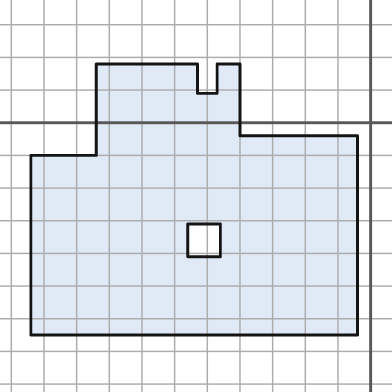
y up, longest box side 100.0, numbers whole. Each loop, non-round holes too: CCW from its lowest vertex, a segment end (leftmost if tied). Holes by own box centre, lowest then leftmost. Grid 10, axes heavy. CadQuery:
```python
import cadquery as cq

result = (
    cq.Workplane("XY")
    .moveTo(-104.0, -65.0)
    .lineTo(-4.0, -65.0)
    .lineTo(-4.0, -4.0)
    .lineTo(-40.0, -4.0)
    .lineTo(-40.0, 18.0)
    .lineTo(-47.0, 18.0)
    .lineTo(-47.0, 9.0)
    .lineTo(-53.0, 9.0)
    .lineTo(-53.0, 18.0)
    .lineTo(-84.0, 18.0)
    .lineTo(-84.0, -10.0)
    .lineTo(-104.0, -10.0)
    .close()
    .moveTo(-56.0, -41.0)
    .lineTo(-46.0, -41.0)
    .lineTo(-46.0, -31.0)
    .lineTo(-56.0, -31.0)
    .close()
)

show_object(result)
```